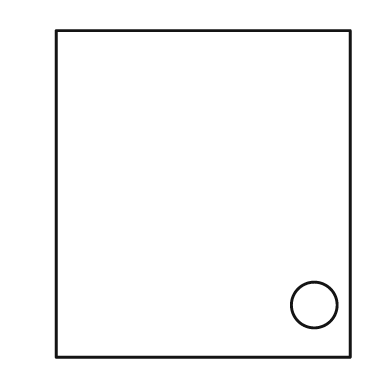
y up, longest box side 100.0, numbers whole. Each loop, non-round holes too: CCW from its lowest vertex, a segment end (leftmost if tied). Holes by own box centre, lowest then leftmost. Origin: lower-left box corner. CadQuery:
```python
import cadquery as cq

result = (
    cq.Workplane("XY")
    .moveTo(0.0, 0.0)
    .lineTo(90.0, 0.0)
    .lineTo(90.0, 100.0)
    .lineTo(0.0, 100.0)
    .close()
    .moveTo(79.0, 16.0)
    .circle(7.0)
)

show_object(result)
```